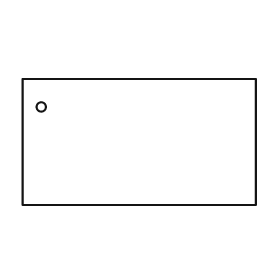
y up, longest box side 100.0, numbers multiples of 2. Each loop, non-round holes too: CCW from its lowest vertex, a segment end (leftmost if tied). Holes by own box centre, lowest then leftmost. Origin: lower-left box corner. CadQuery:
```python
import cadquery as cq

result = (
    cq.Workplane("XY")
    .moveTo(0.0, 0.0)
    .lineTo(100.0, 0.0)
    .lineTo(100.0, 54.0)
    .lineTo(0.0, 54.0)
    .close()
    .moveTo(8.0, 42.0)
    .circle(2.0)
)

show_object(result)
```